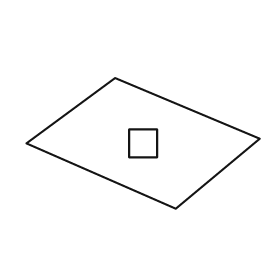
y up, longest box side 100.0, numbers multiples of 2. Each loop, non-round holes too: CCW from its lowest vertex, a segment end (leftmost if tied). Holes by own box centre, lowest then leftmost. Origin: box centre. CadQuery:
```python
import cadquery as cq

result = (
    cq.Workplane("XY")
    .moveTo(14.0, -28.0)
    .lineTo(50.0, 2.0)
    .lineTo(-12.0, 28.0)
    .lineTo(-50.0, 0.0)
    .close()
    .moveTo(-6.0, -6.0)
    .lineTo(6.0, -6.0)
    .lineTo(6.0, 6.0)
    .lineTo(-6.0, 6.0)
    .close()
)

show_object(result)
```